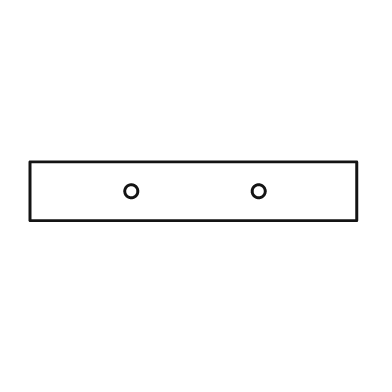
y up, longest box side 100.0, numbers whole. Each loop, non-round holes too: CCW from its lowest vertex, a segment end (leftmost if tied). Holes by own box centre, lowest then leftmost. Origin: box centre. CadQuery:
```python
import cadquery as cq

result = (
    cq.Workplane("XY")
    .moveTo(-50.0, -9.0)
    .lineTo(50.0, -9.0)
    .lineTo(50.0, 9.0)
    .lineTo(-50.0, 9.0)
    .close()
    .moveTo(-19.0, 0.0)
    .circle(2.0)
    .moveTo(20.0, 0.0)
    .circle(2.0)
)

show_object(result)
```